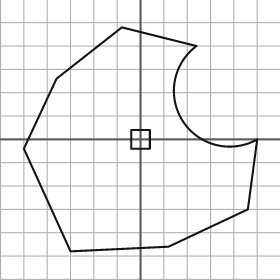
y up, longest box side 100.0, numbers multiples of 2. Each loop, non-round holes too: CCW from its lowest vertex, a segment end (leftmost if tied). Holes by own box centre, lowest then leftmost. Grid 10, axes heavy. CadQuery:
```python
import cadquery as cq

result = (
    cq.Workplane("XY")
    .moveTo(-30.0, -48.0)
    .lineTo(12.0, -46.0)
    .lineTo(46.0, -30.0)
    .lineTo(50.0, 0.0)
    .threePointArc((18.0, 8.0), (24.0, 40.0))
    .lineTo(-8.0, 48.0)
    .lineTo(-36.0, 26.0)
    .lineTo(-50.0, -4.0)
    .close()
    .moveTo(-4.0, -4.0)
    .lineTo(4.0, -4.0)
    .lineTo(4.0, 4.0)
    .lineTo(-4.0, 4.0)
    .close()
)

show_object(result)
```